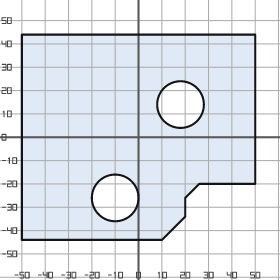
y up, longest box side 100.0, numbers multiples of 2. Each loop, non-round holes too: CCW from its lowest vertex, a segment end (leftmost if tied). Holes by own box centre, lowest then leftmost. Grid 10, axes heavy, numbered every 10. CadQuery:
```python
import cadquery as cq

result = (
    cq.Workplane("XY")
    .moveTo(-50.0, -44.0)
    .lineTo(10.0, -44.0)
    .lineTo(20.0, -34.0)
    .lineTo(20.0, -26.0)
    .lineTo(26.0, -20.0)
    .lineTo(50.0, -20.0)
    .lineTo(50.0, 44.0)
    .lineTo(-50.0, 44.0)
    .close()
    .moveTo(-10.0, -26.0)
    .circle(10.0)
    .moveTo(18.0, 14.0)
    .circle(10.0)
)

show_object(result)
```